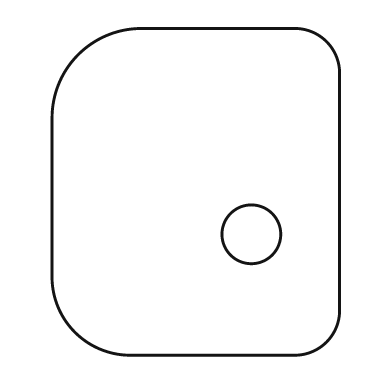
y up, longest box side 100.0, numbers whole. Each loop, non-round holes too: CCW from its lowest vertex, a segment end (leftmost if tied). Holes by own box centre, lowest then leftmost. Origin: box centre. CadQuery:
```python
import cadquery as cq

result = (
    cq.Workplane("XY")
    .moveTo(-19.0, -50.0)
    .lineTo(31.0, -50.0)
    .threePointArc((40.0, -46.0), (44.0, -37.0))
    .lineTo(44.0, 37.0)
    .threePointArc((40.0, 46.0), (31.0, 50.0))
    .lineTo(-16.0, 50.0)
    .threePointArc((-36.0, 42.0), (-44.0, 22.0))
    .lineTo(-44.0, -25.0)
    .threePointArc((-37.0, -43.0), (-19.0, -50.0))
    .close()
    .moveTo(17.0, -13.0)
    .circle(9.0)
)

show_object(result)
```